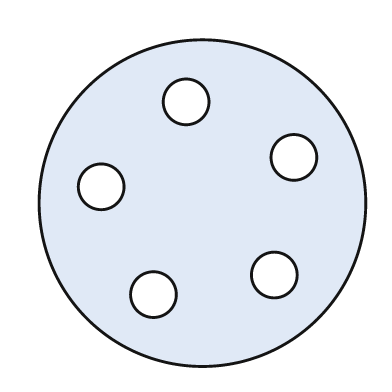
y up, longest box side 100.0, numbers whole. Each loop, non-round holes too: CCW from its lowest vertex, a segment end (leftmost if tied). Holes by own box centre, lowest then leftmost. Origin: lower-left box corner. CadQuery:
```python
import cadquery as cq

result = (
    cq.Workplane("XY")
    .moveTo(50.0, 50.0)
    .circle(50.0)
    .moveTo(35.0, 22.0)
    .circle(7.0)
    .moveTo(72.0, 28.0)
    .circle(7.0)
    .moveTo(19.0, 55.0)
    .circle(7.0)
    .moveTo(78.0, 64.0)
    .circle(7.0)
    .moveTo(45.0, 81.0)
    .circle(7.0)
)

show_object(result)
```